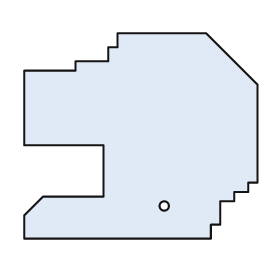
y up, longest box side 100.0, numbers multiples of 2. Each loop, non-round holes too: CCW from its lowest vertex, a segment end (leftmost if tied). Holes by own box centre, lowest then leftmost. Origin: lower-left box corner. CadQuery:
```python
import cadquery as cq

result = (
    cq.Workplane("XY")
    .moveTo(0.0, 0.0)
    .lineTo(80.0, 0.0)
    .lineTo(80.0, 6.0)
    .lineTo(84.0, 6.0)
    .lineTo(84.0, 16.0)
    .lineTo(90.0, 16.0)
    .lineTo(90.0, 20.0)
    .lineTo(96.0, 20.0)
    .lineTo(96.0, 24.0)
    .lineTo(100.0, 24.0)
    .lineTo(100.0, 66.0)
    .lineTo(78.0, 88.0)
    .lineTo(40.0, 88.0)
    .lineTo(40.0, 82.0)
    .lineTo(36.0, 82.0)
    .lineTo(36.0, 76.0)
    .lineTo(22.0, 76.0)
    .lineTo(22.0, 72.0)
    .lineTo(0.0, 72.0)
    .lineTo(0.0, 40.0)
    .lineTo(34.0, 40.0)
    .lineTo(34.0, 18.0)
    .lineTo(8.0, 18.0)
    .lineTo(0.0, 10.0)
    .close()
    .moveTo(60.0, 14.0)
    .circle(2.0)
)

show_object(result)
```